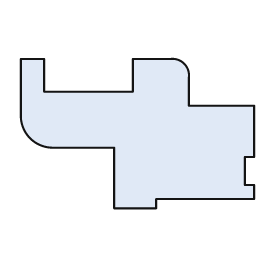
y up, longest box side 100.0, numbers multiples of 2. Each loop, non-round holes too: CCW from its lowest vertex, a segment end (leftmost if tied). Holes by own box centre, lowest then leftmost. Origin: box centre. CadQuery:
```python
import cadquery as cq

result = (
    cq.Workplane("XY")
    .moveTo(-10.0, -32.0)
    .lineTo(8.0, -32.0)
    .lineTo(8.0, -28.0)
    .lineTo(50.0, -28.0)
    .lineTo(50.0, -22.0)
    .lineTo(46.0, -22.0)
    .lineTo(46.0, -10.0)
    .lineTo(50.0, -10.0)
    .lineTo(50.0, 12.0)
    .lineTo(22.0, 12.0)
    .lineTo(22.0, 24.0)
    .threePointArc((20.0, 30.0), (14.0, 32.0))
    .lineTo(-2.0, 32.0)
    .lineTo(-2.0, 18.0)
    .lineTo(-40.0, 18.0)
    .lineTo(-40.0, 32.0)
    .lineTo(-50.0, 32.0)
    .lineTo(-50.0, 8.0)
    .threePointArc((-46.0, -2.0), (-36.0, -6.0))
    .lineTo(-10.0, -6.0)
    .close()
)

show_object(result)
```